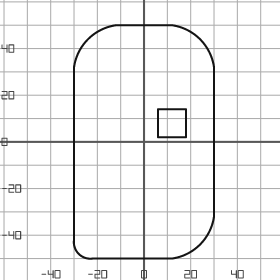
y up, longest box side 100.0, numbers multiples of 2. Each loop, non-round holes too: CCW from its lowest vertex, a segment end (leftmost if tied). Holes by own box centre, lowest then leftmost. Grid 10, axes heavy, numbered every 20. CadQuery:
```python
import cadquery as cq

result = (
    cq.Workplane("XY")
    .moveTo(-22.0, -50.0)
    .lineTo(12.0, -50.0)
    .threePointArc((24.0, -44.0), (30.0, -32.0))
    .lineTo(30.0, 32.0)
    .threePointArc((24.0, 44.0), (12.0, 50.0))
    .lineTo(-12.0, 50.0)
    .threePointArc((-24.0, 44.0), (-30.0, 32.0))
    .lineTo(-30.0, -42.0)
    .threePointArc((-28.0, -48.0), (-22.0, -50.0))
    .close()
    .moveTo(6.0, 2.0)
    .lineTo(18.0, 2.0)
    .lineTo(18.0, 14.0)
    .lineTo(6.0, 14.0)
    .close()
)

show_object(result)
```